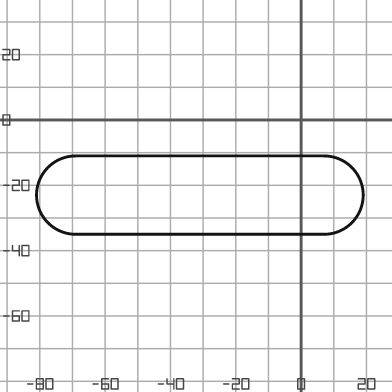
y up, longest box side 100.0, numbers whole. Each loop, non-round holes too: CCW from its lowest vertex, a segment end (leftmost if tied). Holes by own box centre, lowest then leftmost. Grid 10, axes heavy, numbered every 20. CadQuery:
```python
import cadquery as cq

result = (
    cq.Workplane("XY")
    .moveTo(-69.0, -35.0)
    .lineTo(7.0, -35.0)
    .threePointArc((19.0, -23.0), (7.0, -11.0))
    .lineTo(-69.0, -11.0)
    .threePointArc((-81.0, -23.0), (-69.0, -35.0))
    .close()
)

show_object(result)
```